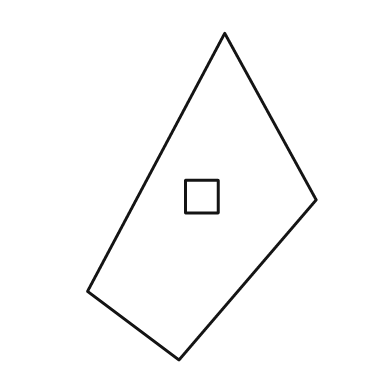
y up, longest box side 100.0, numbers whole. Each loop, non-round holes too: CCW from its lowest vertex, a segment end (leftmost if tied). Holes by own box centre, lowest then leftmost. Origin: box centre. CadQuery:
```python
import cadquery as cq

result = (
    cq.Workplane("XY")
    .moveTo(-7.0, -50.0)
    .lineTo(35.0, -1.0)
    .lineTo(7.0, 50.0)
    .lineTo(-35.0, -29.0)
    .close()
    .moveTo(-5.0, -5.0)
    .lineTo(5.0, -5.0)
    .lineTo(5.0, 5.0)
    .lineTo(-5.0, 5.0)
    .close()
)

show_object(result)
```